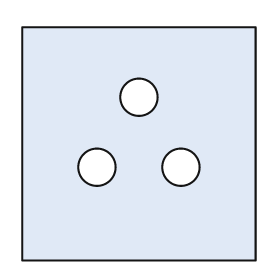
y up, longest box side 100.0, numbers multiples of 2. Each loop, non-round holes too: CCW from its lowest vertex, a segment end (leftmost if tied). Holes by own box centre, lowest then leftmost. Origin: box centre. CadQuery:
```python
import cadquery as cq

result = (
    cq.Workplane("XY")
    .moveTo(-50.0, -50.0)
    .lineTo(50.0, -50.0)
    .lineTo(50.0, 50.0)
    .lineTo(-50.0, 50.0)
    .close()
    .moveTo(-18.0, -10.0)
    .circle(8.0)
    .moveTo(18.0, -10.0)
    .circle(8.0)
    .moveTo(0.0, 20.0)
    .circle(8.0)
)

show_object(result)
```